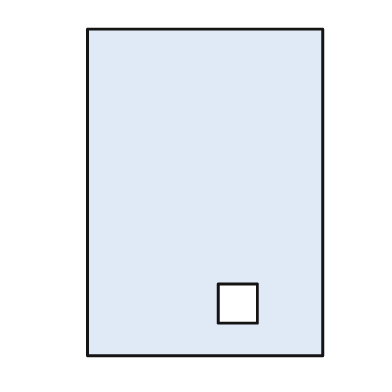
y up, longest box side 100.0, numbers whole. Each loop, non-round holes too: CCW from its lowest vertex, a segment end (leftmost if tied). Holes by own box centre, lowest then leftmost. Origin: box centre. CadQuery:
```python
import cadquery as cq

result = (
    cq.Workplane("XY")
    .moveTo(-36.0, -50.0)
    .lineTo(36.0, -50.0)
    .lineTo(36.0, 50.0)
    .lineTo(-36.0, 50.0)
    .close()
    .moveTo(4.0, -40.0)
    .lineTo(16.0, -40.0)
    .lineTo(16.0, -28.0)
    .lineTo(4.0, -28.0)
    .close()
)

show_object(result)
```